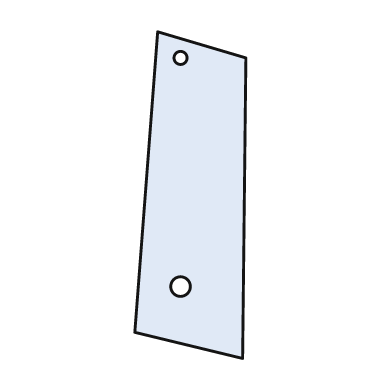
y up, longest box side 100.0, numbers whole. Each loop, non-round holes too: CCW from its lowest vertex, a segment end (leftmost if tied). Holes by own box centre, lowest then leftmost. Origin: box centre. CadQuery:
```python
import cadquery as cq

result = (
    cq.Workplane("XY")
    .moveTo(16.0, -50.0)
    .lineTo(17.0, 42.0)
    .lineTo(-10.0, 50.0)
    .lineTo(-17.0, -42.0)
    .close()
    .moveTo(-3.0, -28.0)
    .circle(3.0)
    .moveTo(-3.0, 42.0)
    .circle(2.0)
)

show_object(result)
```